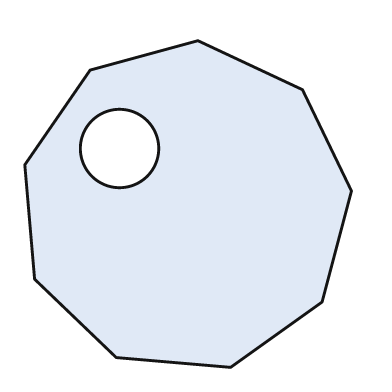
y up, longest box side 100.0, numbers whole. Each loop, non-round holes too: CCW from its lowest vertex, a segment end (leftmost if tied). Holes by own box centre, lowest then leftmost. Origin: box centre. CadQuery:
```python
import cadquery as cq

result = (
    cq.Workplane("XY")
    .moveTo(13.0, -50.0)
    .lineTo(41.0, -30.0)
    .lineTo(50.0, 4.0)
    .lineTo(35.0, 35.0)
    .lineTo(3.0, 50.0)
    .lineTo(-30.0, 41.0)
    .lineTo(-50.0, 12.0)
    .lineTo(-47.0, -23.0)
    .lineTo(-22.0, -47.0)
    .close()
    .moveTo(-21.0, 17.0)
    .circle(12.0)
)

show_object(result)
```